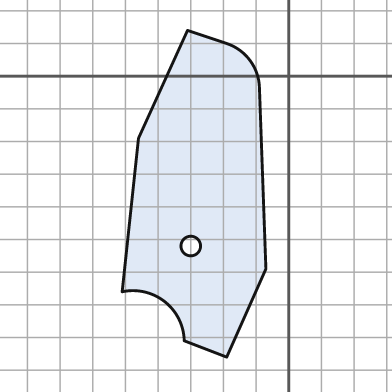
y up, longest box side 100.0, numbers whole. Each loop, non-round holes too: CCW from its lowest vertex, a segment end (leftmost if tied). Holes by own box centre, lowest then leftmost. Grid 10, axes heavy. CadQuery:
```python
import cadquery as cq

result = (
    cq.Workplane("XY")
    .moveTo(-19.0, -86.0)
    .lineTo(-7.0, -59.0)
    .lineTo(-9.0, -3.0)
    .threePointArc((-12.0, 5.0), (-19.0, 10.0))
    .lineTo(-31.0, 14.0)
    .lineTo(-46.0, -19.0)
    .lineTo(-51.0, -66.0)
    .threePointArc((-38.0, -69.0), (-32.0, -81.0))
    .close()
    .moveTo(-30.0, -52.0)
    .circle(3.0)
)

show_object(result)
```